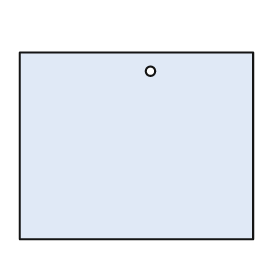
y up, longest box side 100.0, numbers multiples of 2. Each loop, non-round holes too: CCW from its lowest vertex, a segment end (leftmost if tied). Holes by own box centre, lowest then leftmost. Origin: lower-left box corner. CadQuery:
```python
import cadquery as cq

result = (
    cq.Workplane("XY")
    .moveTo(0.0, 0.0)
    .lineTo(100.0, 0.0)
    .lineTo(100.0, 80.0)
    .lineTo(0.0, 80.0)
    .close()
    .moveTo(56.0, 72.0)
    .circle(2.0)
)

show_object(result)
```